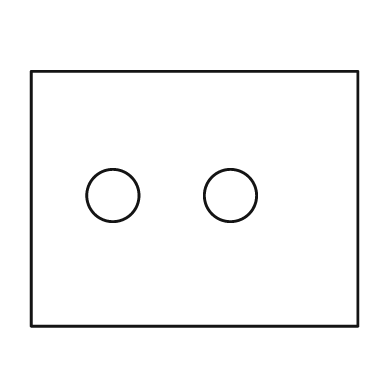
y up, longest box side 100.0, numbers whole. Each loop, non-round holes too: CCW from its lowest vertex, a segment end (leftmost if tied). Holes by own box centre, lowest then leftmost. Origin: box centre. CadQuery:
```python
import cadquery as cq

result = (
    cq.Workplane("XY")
    .moveTo(-50.0, -39.0)
    .lineTo(50.0, -39.0)
    .lineTo(50.0, 39.0)
    .lineTo(-50.0, 39.0)
    .close()
    .moveTo(-25.0, 1.0)
    .circle(8.0)
    .moveTo(11.0, 1.0)
    .circle(8.0)
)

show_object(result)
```